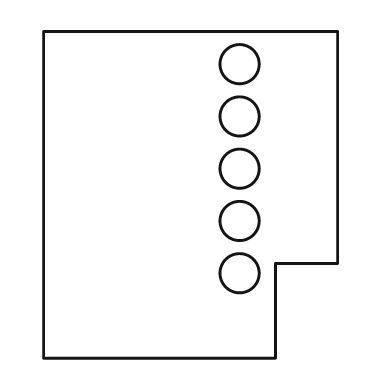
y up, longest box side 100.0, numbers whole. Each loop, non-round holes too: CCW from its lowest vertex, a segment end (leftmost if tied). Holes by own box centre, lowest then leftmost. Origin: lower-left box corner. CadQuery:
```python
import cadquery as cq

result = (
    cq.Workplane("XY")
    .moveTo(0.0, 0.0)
    .lineTo(71.0, 0.0)
    .lineTo(71.0, 29.0)
    .lineTo(90.0, 29.0)
    .lineTo(90.0, 100.0)
    .lineTo(0.0, 100.0)
    .close()
    .moveTo(60.0, 26.0)
    .circle(6.0)
    .moveTo(60.0, 42.0)
    .circle(6.0)
    .moveTo(60.0, 58.0)
    .circle(6.0)
    .moveTo(60.0, 74.0)
    .circle(6.0)
    .moveTo(60.0, 90.0)
    .circle(6.0)
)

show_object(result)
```